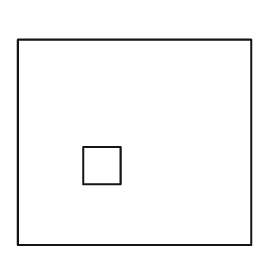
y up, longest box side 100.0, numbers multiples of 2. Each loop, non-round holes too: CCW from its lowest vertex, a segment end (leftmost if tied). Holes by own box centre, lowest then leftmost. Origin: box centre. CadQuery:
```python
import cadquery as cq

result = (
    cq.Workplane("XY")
    .moveTo(-50.0, -44.0)
    .lineTo(50.0, -44.0)
    .lineTo(50.0, 44.0)
    .lineTo(-50.0, 44.0)
    .close()
    .moveTo(-22.0, -18.0)
    .lineTo(-6.0, -18.0)
    .lineTo(-6.0, -2.0)
    .lineTo(-22.0, -2.0)
    .close()
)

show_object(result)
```